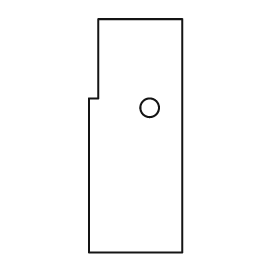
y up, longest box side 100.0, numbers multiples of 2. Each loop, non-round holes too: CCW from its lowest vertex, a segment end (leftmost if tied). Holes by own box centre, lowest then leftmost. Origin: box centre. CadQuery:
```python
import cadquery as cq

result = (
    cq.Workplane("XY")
    .moveTo(-20.0, -50.0)
    .lineTo(20.0, -50.0)
    .lineTo(20.0, 50.0)
    .lineTo(-16.0, 50.0)
    .lineTo(-16.0, 16.0)
    .lineTo(-20.0, 16.0)
    .close()
    .moveTo(6.0, 12.0)
    .circle(4.0)
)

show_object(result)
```